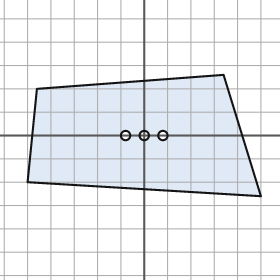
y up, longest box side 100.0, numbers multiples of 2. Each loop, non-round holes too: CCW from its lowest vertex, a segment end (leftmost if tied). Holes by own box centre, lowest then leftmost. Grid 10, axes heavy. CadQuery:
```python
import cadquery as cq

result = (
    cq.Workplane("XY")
    .moveTo(50.0, -26.0)
    .lineTo(34.0, 26.0)
    .lineTo(-46.0, 20.0)
    .lineTo(-50.0, -20.0)
    .close()
    .moveTo(-8.0, 0.0)
    .circle(2.0)
    .moveTo(0.0, 0.0)
    .circle(2.0)
    .moveTo(8.0, 0.0)
    .circle(2.0)
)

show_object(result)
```